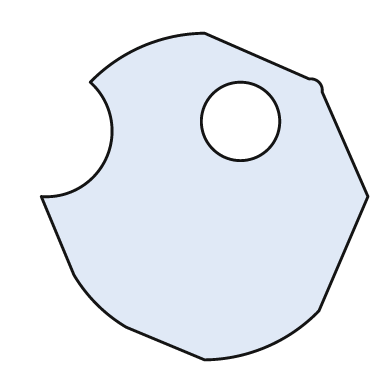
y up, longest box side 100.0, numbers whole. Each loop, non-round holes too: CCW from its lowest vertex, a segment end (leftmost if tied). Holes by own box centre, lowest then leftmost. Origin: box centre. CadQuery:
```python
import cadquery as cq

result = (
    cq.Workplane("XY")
    .moveTo(0.0, -50.0)
    .threePointArc((19.0, -46.0), (35.0, -35.0))
    .lineTo(50.0, 0.0)
    .lineTo(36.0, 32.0)
    .threePointArc((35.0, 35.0), (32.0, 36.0))
    .lineTo(0.0, 50.0)
    .threePointArc((-19.0, 46.0), (-35.0, 35.0))
    .threePointArc((-30.0, 12.0), (-50.0, 0.0))
    .lineTo(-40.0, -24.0)
    .threePointArc((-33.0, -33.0), (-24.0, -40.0))
    .close()
    .moveTo(11.0, 23.0)
    .circle(12.0)
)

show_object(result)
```